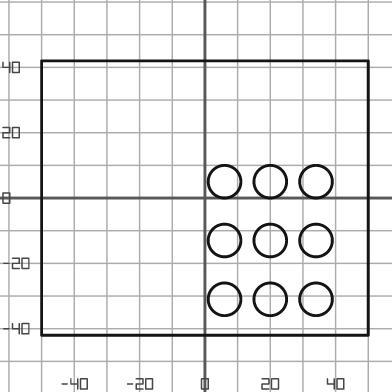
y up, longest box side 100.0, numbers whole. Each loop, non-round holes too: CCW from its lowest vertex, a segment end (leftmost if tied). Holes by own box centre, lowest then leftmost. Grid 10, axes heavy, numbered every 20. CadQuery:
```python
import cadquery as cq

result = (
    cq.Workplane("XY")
    .moveTo(-50.0, -42.0)
    .lineTo(50.0, -42.0)
    .lineTo(50.0, 42.0)
    .lineTo(-50.0, 42.0)
    .close()
    .moveTo(6.0, -31.0)
    .circle(5.0)
    .moveTo(20.0, -31.0)
    .circle(5.0)
    .moveTo(34.0, -31.0)
    .circle(5.0)
    .moveTo(6.0, -13.0)
    .circle(5.0)
    .moveTo(20.0, -13.0)
    .circle(5.0)
    .moveTo(34.0, -13.0)
    .circle(5.0)
    .moveTo(6.0, 5.0)
    .circle(5.0)
    .moveTo(20.0, 5.0)
    .circle(5.0)
    .moveTo(34.0, 5.0)
    .circle(5.0)
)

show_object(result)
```